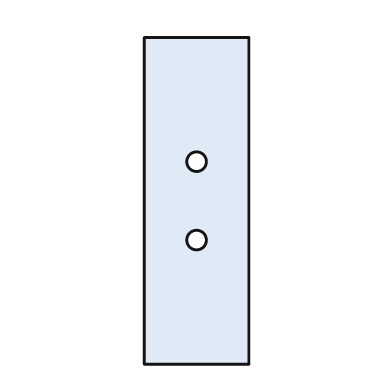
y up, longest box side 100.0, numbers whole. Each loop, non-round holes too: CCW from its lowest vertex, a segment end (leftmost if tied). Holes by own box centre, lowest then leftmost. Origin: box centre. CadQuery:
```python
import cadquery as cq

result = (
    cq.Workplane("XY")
    .moveTo(-16.0, -50.0)
    .lineTo(16.0, -50.0)
    .lineTo(16.0, 50.0)
    .lineTo(-16.0, 50.0)
    .close()
    .moveTo(0.0, -12.0)
    .circle(3.0)
    .moveTo(0.0, 12.0)
    .circle(3.0)
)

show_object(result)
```